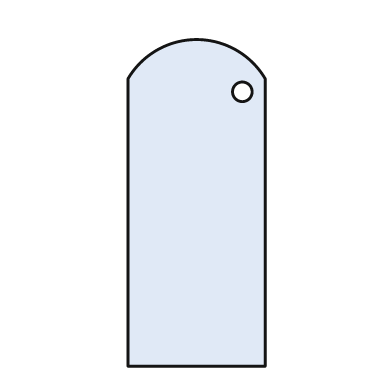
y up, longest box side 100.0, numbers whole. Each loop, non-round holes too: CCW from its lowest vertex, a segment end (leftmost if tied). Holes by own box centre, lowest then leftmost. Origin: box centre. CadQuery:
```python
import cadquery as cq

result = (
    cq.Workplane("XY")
    .moveTo(-21.0, -50.0)
    .lineTo(21.0, -50.0)
    .lineTo(21.0, 38.0)
    .threePointArc((0.0, 50.0), (-21.0, 38.0))
    .close()
    .moveTo(14.0, 34.0)
    .circle(3.0)
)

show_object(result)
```